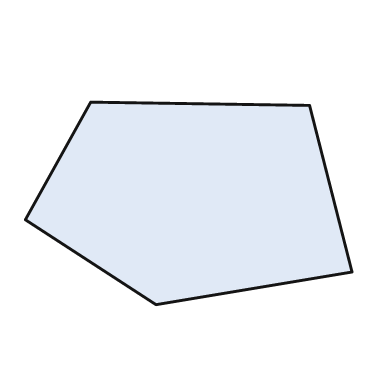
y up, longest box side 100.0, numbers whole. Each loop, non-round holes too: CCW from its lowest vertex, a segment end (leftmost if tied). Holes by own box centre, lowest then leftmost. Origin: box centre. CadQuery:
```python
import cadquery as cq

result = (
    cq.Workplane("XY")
    .moveTo(-10.0, -31.0)
    .lineTo(50.0, -21.0)
    .lineTo(37.0, 30.0)
    .lineTo(-30.0, 31.0)
    .lineTo(-50.0, -5.0)
    .close()
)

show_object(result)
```